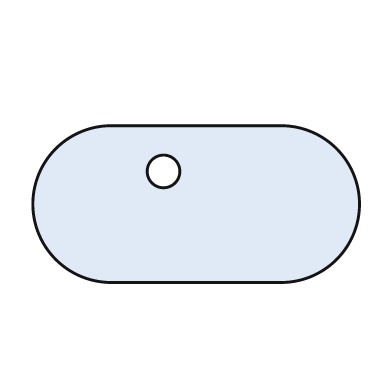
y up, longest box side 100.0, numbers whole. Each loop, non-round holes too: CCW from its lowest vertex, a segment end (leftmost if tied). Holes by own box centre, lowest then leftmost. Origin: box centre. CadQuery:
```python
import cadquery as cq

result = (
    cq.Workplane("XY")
    .moveTo(-26.0, -24.0)
    .lineTo(26.0, -24.0)
    .threePointArc((50.0, 0.0), (26.0, 24.0))
    .lineTo(-26.0, 24.0)
    .threePointArc((-50.0, 0.0), (-26.0, -24.0))
    .close()
    .moveTo(-10.0, 10.0)
    .circle(5.0)
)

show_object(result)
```